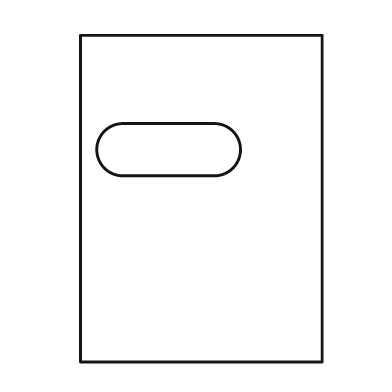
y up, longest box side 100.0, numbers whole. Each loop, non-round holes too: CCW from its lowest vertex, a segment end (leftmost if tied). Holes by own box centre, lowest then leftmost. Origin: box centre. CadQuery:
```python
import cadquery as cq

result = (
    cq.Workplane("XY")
    .moveTo(-37.0, -50.0)
    .lineTo(37.0, -50.0)
    .lineTo(37.0, 50.0)
    .lineTo(-37.0, 50.0)
    .close()
    .moveTo(-24.0, 7.0)
    .lineTo(4.0, 7.0)
    .threePointArc((12.0, 15.0), (4.0, 23.0))
    .lineTo(-24.0, 23.0)
    .threePointArc((-32.0, 15.0), (-24.0, 7.0))
    .close()
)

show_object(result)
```